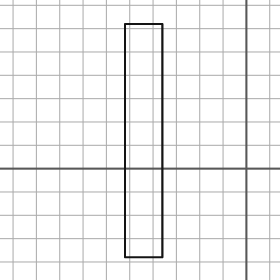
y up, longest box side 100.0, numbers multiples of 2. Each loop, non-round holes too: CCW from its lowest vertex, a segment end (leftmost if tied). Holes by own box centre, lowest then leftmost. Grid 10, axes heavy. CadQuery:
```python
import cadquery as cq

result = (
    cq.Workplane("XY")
    .moveTo(-52.0, -38.0)
    .lineTo(-36.0, -38.0)
    .lineTo(-36.0, 62.0)
    .lineTo(-52.0, 62.0)
    .close()
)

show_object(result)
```